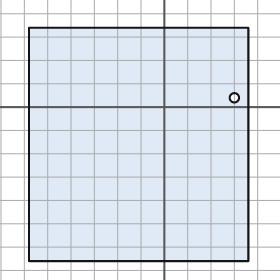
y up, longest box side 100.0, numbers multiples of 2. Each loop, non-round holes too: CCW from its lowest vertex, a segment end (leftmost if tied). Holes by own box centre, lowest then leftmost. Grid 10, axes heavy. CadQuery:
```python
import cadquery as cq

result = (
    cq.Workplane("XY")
    .moveTo(-58.0, -66.0)
    .lineTo(36.0, -66.0)
    .lineTo(36.0, 34.0)
    .lineTo(-58.0, 34.0)
    .close()
    .moveTo(30.0, 4.0)
    .circle(2.0)
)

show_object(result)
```